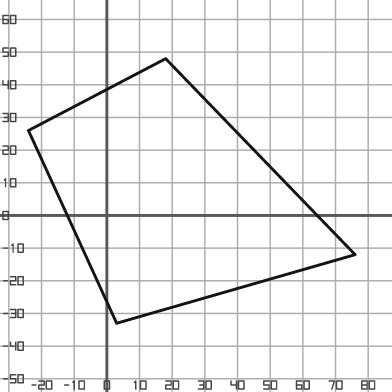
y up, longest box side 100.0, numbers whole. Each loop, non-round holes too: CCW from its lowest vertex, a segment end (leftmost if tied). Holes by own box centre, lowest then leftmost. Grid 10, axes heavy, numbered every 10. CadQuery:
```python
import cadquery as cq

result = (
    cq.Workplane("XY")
    .moveTo(3.0, -33.0)
    .lineTo(76.0, -12.0)
    .lineTo(18.0, 48.0)
    .lineTo(-24.0, 26.0)
    .close()
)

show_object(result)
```